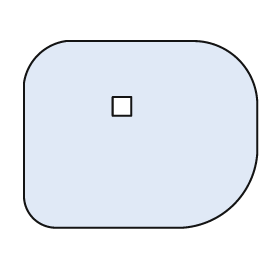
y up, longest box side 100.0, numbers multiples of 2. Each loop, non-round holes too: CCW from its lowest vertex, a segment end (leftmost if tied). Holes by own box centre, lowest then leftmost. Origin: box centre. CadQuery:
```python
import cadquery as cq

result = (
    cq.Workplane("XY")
    .moveTo(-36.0, -40.0)
    .lineTo(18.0, -40.0)
    .threePointArc((40.0, -30.0), (50.0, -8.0))
    .lineTo(50.0, 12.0)
    .threePointArc((42.0, 32.0), (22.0, 40.0))
    .lineTo(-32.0, 40.0)
    .threePointArc((-44.0, 34.0), (-50.0, 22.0))
    .lineTo(-50.0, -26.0)
    .threePointArc((-46.0, -36.0), (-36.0, -40.0))
    .close()
    .moveTo(-12.0, 8.0)
    .lineTo(-4.0, 8.0)
    .lineTo(-4.0, 16.0)
    .lineTo(-12.0, 16.0)
    .close()
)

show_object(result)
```